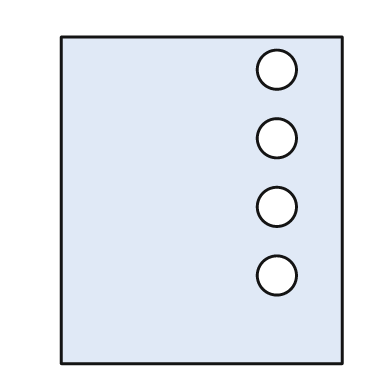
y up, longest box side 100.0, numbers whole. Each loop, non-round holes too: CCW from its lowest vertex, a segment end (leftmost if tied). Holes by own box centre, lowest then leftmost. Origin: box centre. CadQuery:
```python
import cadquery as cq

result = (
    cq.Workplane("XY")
    .moveTo(-43.0, -50.0)
    .lineTo(43.0, -50.0)
    .lineTo(43.0, 50.0)
    .lineTo(-43.0, 50.0)
    .close()
    .moveTo(23.0, -23.0)
    .circle(6.0)
    .moveTo(23.0, -2.0)
    .circle(6.0)
    .moveTo(23.0, 19.0)
    .circle(6.0)
    .moveTo(23.0, 40.0)
    .circle(6.0)
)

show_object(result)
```